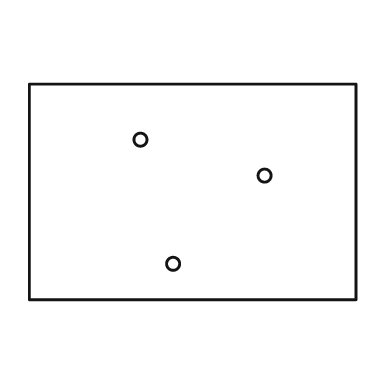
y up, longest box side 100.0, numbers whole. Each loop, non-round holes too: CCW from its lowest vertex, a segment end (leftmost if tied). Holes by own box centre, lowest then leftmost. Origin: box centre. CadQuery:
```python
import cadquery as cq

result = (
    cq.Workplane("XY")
    .moveTo(-50.0, -33.0)
    .lineTo(50.0, -33.0)
    .lineTo(50.0, 33.0)
    .lineTo(-50.0, 33.0)
    .close()
    .moveTo(-6.0, -22.0)
    .circle(2.0)
    .moveTo(22.0, 5.0)
    .circle(2.0)
    .moveTo(-16.0, 16.0)
    .circle(2.0)
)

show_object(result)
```